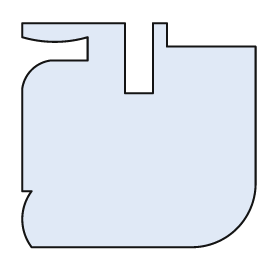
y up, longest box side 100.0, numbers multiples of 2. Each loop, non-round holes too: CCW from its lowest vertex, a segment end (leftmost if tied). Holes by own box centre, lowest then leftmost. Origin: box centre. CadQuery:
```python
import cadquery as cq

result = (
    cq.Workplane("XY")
    .moveTo(-46.0, -48.0)
    .lineTo(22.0, -48.0)
    .threePointArc((42.0, -40.0), (50.0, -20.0))
    .lineTo(50.0, 38.0)
    .lineTo(12.0, 38.0)
    .lineTo(12.0, 48.0)
    .lineTo(6.0, 48.0)
    .lineTo(6.0, 18.0)
    .lineTo(-6.0, 18.0)
    .lineTo(-6.0, 48.0)
    .lineTo(-50.0, 48.0)
    .lineTo(-50.0, 42.0)
    .threePointArc((-36.0, 40.0), (-22.0, 42.0))
    .lineTo(-22.0, 32.0)
    .lineTo(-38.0, 32.0)
    .threePointArc((-46.0, 28.0), (-50.0, 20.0))
    .lineTo(-50.0, -24.0)
    .lineTo(-46.0, -24.0)
    .threePointArc((-50.0, -36.0), (-46.0, -48.0))
    .close()
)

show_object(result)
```